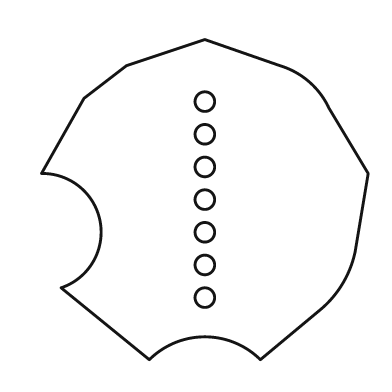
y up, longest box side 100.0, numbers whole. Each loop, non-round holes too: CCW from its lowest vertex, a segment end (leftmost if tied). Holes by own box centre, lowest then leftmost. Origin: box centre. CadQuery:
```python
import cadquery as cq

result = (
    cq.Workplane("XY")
    .moveTo(-17.0, -49.0)
    .threePointArc((0.0, -42.0), (17.0, -49.0))
    .lineTo(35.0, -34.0)
    .threePointArc((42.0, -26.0), (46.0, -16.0))
    .lineTo(50.0, 8.0)
    .lineTo(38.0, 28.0)
    .threePointArc((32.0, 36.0), (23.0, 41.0))
    .lineTo(0.0, 49.0)
    .lineTo(-24.0, 41.0)
    .lineTo(-37.0, 31.0)
    .lineTo(-50.0, 8.0)
    .threePointArc((-32.0, -7.0), (-44.0, -27.0))
    .close()
    .moveTo(0.0, -30.0)
    .circle(3.0)
    .moveTo(0.0, -20.0)
    .circle(3.0)
    .moveTo(0.0, -10.0)
    .circle(3.0)
    .moveTo(0.0, 0.0)
    .circle(3.0)
    .moveTo(0.0, 10.0)
    .circle(3.0)
    .moveTo(0.0, 20.0)
    .circle(3.0)
    .moveTo(0.0, 30.0)
    .circle(3.0)
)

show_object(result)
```